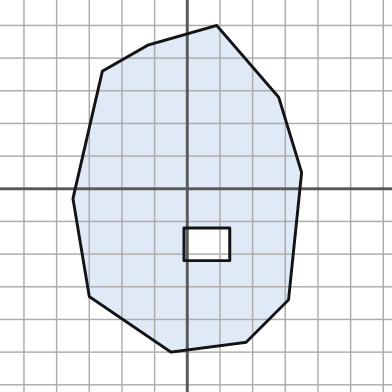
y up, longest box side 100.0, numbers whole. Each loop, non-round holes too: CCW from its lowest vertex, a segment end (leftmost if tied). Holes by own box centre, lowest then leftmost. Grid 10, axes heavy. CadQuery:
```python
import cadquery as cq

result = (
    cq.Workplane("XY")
    .moveTo(-5.0, -50.0)
    .lineTo(18.0, -47.0)
    .lineTo(31.0, -34.0)
    .lineTo(35.0, 5.0)
    .lineTo(28.0, 28.0)
    .lineTo(9.0, 50.0)
    .lineTo(-12.0, 44.0)
    .lineTo(-26.0, 36.0)
    .lineTo(-35.0, -3.0)
    .lineTo(-30.0, -33.0)
    .close()
    .moveTo(-1.0, -22.0)
    .lineTo(13.0, -22.0)
    .lineTo(13.0, -12.0)
    .lineTo(-1.0, -12.0)
    .close()
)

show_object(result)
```